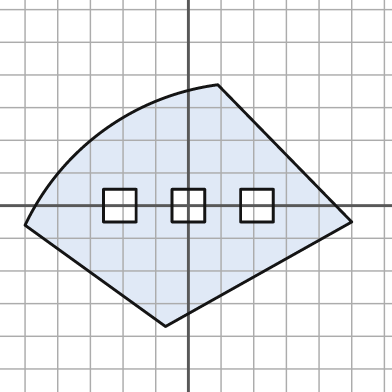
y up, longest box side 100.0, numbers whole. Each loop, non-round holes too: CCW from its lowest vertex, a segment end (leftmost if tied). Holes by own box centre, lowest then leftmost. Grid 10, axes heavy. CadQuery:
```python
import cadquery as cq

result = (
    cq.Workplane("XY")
    .moveTo(-7.0, -37.0)
    .lineTo(50.0, -5.0)
    .lineTo(9.0, 37.0)
    .threePointArc((-26.0, 23.0), (-50.0, -6.0))
    .close()
    .moveTo(-26.0, -5.0)
    .lineTo(-16.0, -5.0)
    .lineTo(-16.0, 5.0)
    .lineTo(-26.0, 5.0)
    .close()
    .moveTo(-5.0, -5.0)
    .lineTo(5.0, -5.0)
    .lineTo(5.0, 5.0)
    .lineTo(-5.0, 5.0)
    .close()
    .moveTo(16.0, -5.0)
    .lineTo(26.0, -5.0)
    .lineTo(26.0, 5.0)
    .lineTo(16.0, 5.0)
    .close()
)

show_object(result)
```